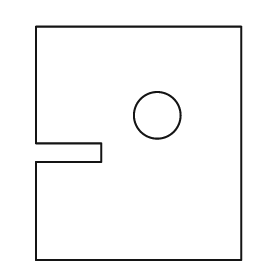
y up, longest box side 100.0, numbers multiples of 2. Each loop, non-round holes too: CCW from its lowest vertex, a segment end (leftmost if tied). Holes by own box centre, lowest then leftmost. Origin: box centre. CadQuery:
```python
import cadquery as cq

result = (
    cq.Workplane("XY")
    .moveTo(-44.0, -50.0)
    .lineTo(44.0, -50.0)
    .lineTo(44.0, 50.0)
    .lineTo(-44.0, 50.0)
    .lineTo(-44.0, 0.0)
    .lineTo(-16.0, 0.0)
    .lineTo(-16.0, -8.0)
    .lineTo(-44.0, -8.0)
    .close()
    .moveTo(8.0, 12.0)
    .circle(10.0)
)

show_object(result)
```